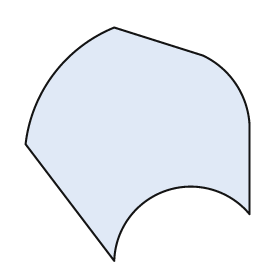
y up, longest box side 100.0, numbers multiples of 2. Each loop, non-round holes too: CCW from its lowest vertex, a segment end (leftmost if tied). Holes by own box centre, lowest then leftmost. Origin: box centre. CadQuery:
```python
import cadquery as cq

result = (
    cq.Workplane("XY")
    .moveTo(-10.0, -50.0)
    .threePointArc((12.0, -20.0), (48.0, -30.0))
    .lineTo(48.0, 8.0)
    .threePointArc((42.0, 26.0), (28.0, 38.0))
    .lineTo(-10.0, 50.0)
    .threePointArc((-36.0, 30.0), (-48.0, 0.0))
    .close()
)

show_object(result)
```